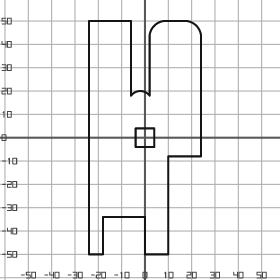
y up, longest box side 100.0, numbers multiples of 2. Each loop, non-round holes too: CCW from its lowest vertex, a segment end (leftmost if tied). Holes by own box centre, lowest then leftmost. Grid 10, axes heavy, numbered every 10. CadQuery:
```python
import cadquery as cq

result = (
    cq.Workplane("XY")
    .moveTo(-24.0, -50.0)
    .lineTo(-18.0, -50.0)
    .lineTo(-18.0, -34.0)
    .lineTo(0.0, -34.0)
    .lineTo(0.0, -50.0)
    .lineTo(10.0, -50.0)
    .lineTo(10.0, -8.0)
    .lineTo(24.0, -8.0)
    .lineTo(24.0, 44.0)
    .threePointArc((22.0, 48.0), (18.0, 50.0))
    .lineTo(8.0, 50.0)
    .threePointArc((4.0, 48.0), (2.0, 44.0))
    .lineTo(2.0, 18.0)
    .threePointArc((-2.0, 20.0), (-6.0, 18.0))
    .lineTo(-6.0, 50.0)
    .lineTo(-24.0, 50.0)
    .close()
    .moveTo(-4.0, -4.0)
    .lineTo(4.0, -4.0)
    .lineTo(4.0, 4.0)
    .lineTo(-4.0, 4.0)
    .close()
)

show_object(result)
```